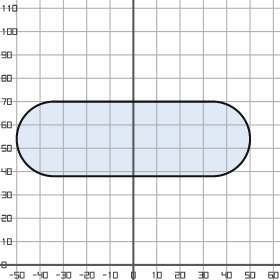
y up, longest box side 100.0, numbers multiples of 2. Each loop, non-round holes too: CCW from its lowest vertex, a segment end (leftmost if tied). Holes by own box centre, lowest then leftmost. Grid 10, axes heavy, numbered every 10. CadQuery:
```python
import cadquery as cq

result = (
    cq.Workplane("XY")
    .moveTo(-34.0, 38.0)
    .lineTo(34.0, 38.0)
    .threePointArc((50.0, 54.0), (34.0, 70.0))
    .lineTo(-34.0, 70.0)
    .threePointArc((-50.0, 54.0), (-34.0, 38.0))
    .close()
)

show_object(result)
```